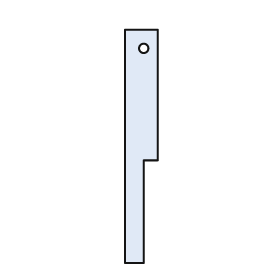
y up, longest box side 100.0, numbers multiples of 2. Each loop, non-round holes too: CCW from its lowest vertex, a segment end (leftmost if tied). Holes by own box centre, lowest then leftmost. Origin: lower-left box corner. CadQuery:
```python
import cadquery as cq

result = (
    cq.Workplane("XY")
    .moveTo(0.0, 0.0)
    .lineTo(8.0, 0.0)
    .lineTo(8.0, 44.0)
    .lineTo(14.0, 44.0)
    .lineTo(14.0, 100.0)
    .lineTo(0.0, 100.0)
    .close()
    .moveTo(8.0, 92.0)
    .circle(2.0)
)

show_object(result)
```